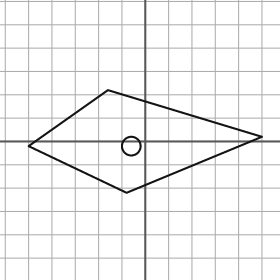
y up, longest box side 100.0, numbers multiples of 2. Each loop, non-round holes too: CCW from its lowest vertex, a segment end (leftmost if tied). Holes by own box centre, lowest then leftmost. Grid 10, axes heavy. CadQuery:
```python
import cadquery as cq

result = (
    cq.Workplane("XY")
    .moveTo(-8.0, -22.0)
    .lineTo(50.0, 2.0)
    .lineTo(-16.0, 22.0)
    .lineTo(-50.0, -2.0)
    .close()
    .moveTo(-6.0, -2.0)
    .circle(4.0)
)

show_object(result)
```